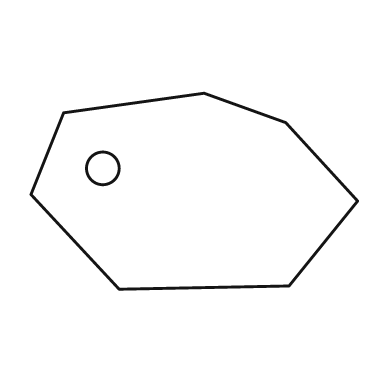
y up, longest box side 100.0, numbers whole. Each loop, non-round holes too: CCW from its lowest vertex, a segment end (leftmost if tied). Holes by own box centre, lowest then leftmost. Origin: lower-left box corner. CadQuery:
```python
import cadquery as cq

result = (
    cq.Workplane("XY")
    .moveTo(27.0, 0.0)
    .lineTo(79.0, 1.0)
    .lineTo(100.0, 27.0)
    .lineTo(78.0, 51.0)
    .lineTo(53.0, 60.0)
    .lineTo(10.0, 54.0)
    .lineTo(0.0, 29.0)
    .close()
    .moveTo(22.0, 37.0)
    .circle(5.0)
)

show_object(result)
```